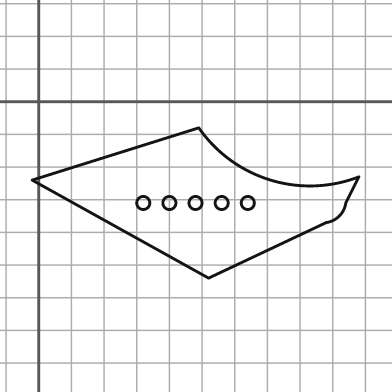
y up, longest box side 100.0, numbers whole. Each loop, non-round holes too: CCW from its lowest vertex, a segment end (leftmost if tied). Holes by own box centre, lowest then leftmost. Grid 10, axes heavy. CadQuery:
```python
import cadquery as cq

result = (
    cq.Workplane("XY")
    .moveTo(52.0, -54.0)
    .lineTo(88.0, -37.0)
    .threePointArc((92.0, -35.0), (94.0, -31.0))
    .lineTo(98.0, -23.0)
    .threePointArc((71.0, -24.0), (49.0, -8.0))
    .lineTo(-2.0, -24.0)
    .close()
    .moveTo(32.0, -31.0)
    .circle(2.0)
    .moveTo(40.0, -31.0)
    .circle(2.0)
    .moveTo(48.0, -31.0)
    .circle(2.0)
    .moveTo(56.0, -31.0)
    .circle(2.0)
    .moveTo(64.0, -31.0)
    .circle(2.0)
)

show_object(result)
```